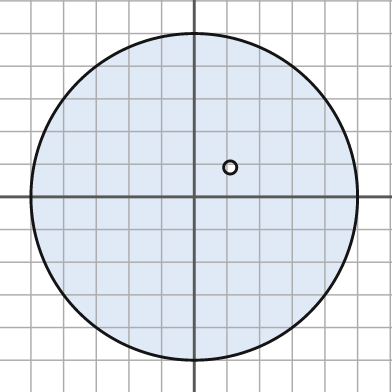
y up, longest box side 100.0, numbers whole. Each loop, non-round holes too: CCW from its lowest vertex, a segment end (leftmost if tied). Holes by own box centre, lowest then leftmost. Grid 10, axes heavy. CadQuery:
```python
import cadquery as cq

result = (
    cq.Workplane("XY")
    .moveTo(0.0, 0.0)
    .circle(50.0)
    .moveTo(11.0, 9.0)
    .circle(2.0)
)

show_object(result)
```